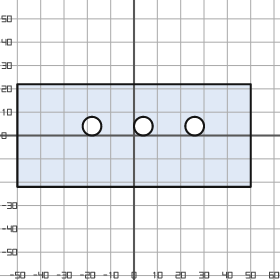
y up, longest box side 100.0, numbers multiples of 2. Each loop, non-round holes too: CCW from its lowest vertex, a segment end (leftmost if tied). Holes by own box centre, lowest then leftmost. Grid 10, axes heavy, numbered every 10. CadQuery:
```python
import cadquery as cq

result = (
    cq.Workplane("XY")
    .moveTo(-50.0, -22.0)
    .lineTo(50.0, -22.0)
    .lineTo(50.0, 22.0)
    .lineTo(-50.0, 22.0)
    .close()
    .moveTo(-18.0, 4.0)
    .circle(4.0)
    .moveTo(4.0, 4.0)
    .circle(4.0)
    .moveTo(26.0, 4.0)
    .circle(4.0)
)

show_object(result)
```